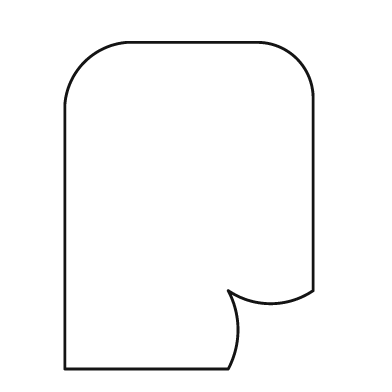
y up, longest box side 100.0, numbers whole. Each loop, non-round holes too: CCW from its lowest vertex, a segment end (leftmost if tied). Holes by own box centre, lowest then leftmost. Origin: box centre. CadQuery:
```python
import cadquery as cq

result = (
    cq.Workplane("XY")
    .moveTo(-38.0, -50.0)
    .lineTo(12.0, -50.0)
    .threePointArc((15.0, -38.0), (12.0, -26.0))
    .threePointArc((25.0, -30.0), (38.0, -26.0))
    .lineTo(38.0, 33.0)
    .threePointArc((33.0, 45.0), (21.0, 50.0))
    .lineTo(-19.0, 50.0)
    .threePointArc((-32.0, 44.0), (-38.0, 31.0))
    .close()
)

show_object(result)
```